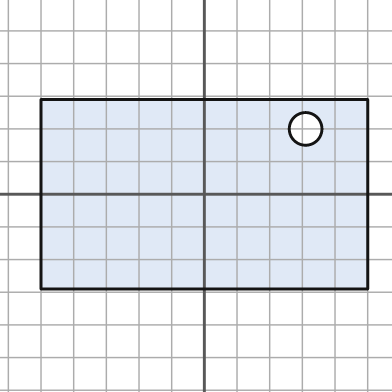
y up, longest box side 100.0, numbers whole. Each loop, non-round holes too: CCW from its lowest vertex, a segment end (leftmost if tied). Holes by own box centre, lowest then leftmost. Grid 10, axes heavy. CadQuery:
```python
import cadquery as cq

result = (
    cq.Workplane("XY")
    .moveTo(-50.0, -29.0)
    .lineTo(50.0, -29.0)
    .lineTo(50.0, 29.0)
    .lineTo(-50.0, 29.0)
    .close()
    .moveTo(31.0, 20.0)
    .circle(5.0)
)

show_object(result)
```